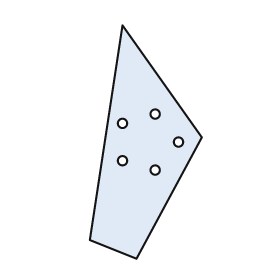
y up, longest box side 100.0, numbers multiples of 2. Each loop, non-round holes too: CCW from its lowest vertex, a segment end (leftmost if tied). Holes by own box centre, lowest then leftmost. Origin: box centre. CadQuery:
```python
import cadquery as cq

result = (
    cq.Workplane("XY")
    .moveTo(-4.0, -50.0)
    .lineTo(24.0, 2.0)
    .lineTo(-10.0, 50.0)
    .lineTo(-24.0, -42.0)
    .close()
    .moveTo(4.0, -12.0)
    .circle(2.0)
    .moveTo(-10.0, -8.0)
    .circle(2.0)
    .moveTo(14.0, 0.0)
    .circle(2.0)
    .moveTo(-10.0, 8.0)
    .circle(2.0)
    .moveTo(4.0, 12.0)
    .circle(2.0)
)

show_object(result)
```